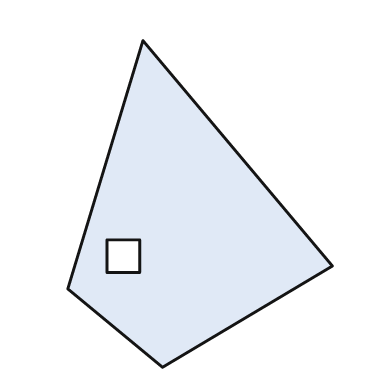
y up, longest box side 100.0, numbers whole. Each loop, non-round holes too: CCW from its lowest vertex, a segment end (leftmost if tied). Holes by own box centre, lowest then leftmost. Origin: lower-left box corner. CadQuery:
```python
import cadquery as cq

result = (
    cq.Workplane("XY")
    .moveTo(29.0, 0.0)
    .lineTo(81.0, 31.0)
    .lineTo(23.0, 100.0)
    .lineTo(0.0, 24.0)
    .close()
    .moveTo(12.0, 29.0)
    .lineTo(22.0, 29.0)
    .lineTo(22.0, 39.0)
    .lineTo(12.0, 39.0)
    .close()
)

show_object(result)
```